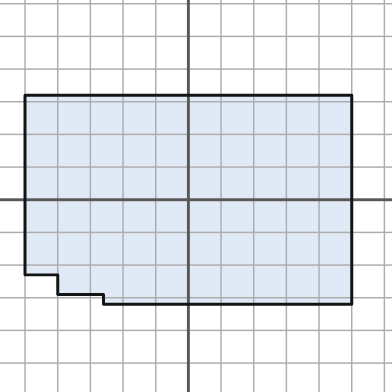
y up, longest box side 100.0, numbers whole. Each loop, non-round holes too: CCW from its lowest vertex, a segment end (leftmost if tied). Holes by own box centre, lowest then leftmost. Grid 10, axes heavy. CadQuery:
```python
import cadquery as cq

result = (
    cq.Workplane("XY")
    .moveTo(-26.0, -32.0)
    .lineTo(50.0, -32.0)
    .lineTo(50.0, 32.0)
    .lineTo(-50.0, 32.0)
    .lineTo(-50.0, -23.0)
    .lineTo(-40.0, -23.0)
    .lineTo(-40.0, -29.0)
    .lineTo(-26.0, -29.0)
    .close()
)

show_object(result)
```